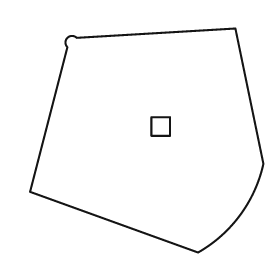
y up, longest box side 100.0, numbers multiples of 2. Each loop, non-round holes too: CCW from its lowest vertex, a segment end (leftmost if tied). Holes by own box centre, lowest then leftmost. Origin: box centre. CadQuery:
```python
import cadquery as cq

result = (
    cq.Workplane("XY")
    .moveTo(22.0, -48.0)
    .threePointArc((40.0, -32.0), (50.0, -10.0))
    .lineTo(38.0, 48.0)
    .lineTo(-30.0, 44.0)
    .threePointArc((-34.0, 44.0), (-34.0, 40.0))
    .lineTo(-50.0, -22.0)
    .close()
    .moveTo(2.0, 2.0)
    .lineTo(10.0, 2.0)
    .lineTo(10.0, 10.0)
    .lineTo(2.0, 10.0)
    .close()
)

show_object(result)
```